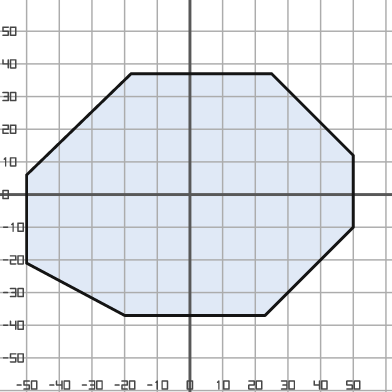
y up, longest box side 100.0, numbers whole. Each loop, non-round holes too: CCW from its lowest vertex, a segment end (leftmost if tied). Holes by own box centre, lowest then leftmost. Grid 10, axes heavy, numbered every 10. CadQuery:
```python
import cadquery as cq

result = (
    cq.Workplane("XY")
    .moveTo(-20.0, -37.0)
    .lineTo(23.0, -37.0)
    .lineTo(50.0, -10.0)
    .lineTo(50.0, 12.0)
    .lineTo(25.0, 37.0)
    .lineTo(-18.0, 37.0)
    .lineTo(-50.0, 6.0)
    .lineTo(-50.0, -21.0)
    .close()
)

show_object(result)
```